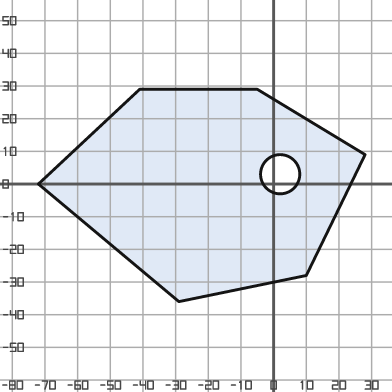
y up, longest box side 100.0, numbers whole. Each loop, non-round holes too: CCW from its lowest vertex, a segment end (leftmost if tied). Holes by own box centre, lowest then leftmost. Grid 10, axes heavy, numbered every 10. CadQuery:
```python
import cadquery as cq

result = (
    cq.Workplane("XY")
    .moveTo(-29.0, -36.0)
    .lineTo(10.0, -28.0)
    .lineTo(28.0, 9.0)
    .lineTo(-5.0, 29.0)
    .lineTo(-41.0, 29.0)
    .lineTo(-72.0, 0.0)
    .close()
    .moveTo(2.0, 3.0)
    .circle(6.0)
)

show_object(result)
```